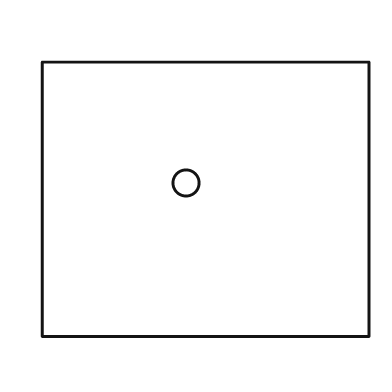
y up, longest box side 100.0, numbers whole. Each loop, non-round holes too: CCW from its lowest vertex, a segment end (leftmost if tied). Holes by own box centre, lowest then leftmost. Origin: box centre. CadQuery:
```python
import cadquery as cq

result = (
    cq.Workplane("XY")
    .moveTo(-50.0, -42.0)
    .lineTo(50.0, -42.0)
    .lineTo(50.0, 42.0)
    .lineTo(-50.0, 42.0)
    .close()
    .moveTo(-6.0, 5.0)
    .circle(4.0)
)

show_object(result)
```